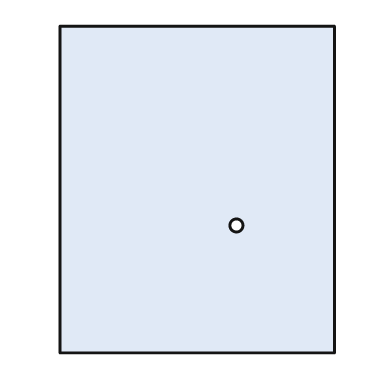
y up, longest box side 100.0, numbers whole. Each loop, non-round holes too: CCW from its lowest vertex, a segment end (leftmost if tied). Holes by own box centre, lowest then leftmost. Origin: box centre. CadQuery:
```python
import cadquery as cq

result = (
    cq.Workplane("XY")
    .moveTo(-42.0, -50.0)
    .lineTo(42.0, -50.0)
    .lineTo(42.0, 50.0)
    .lineTo(-42.0, 50.0)
    .close()
    .moveTo(12.0, -11.0)
    .circle(2.0)
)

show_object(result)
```